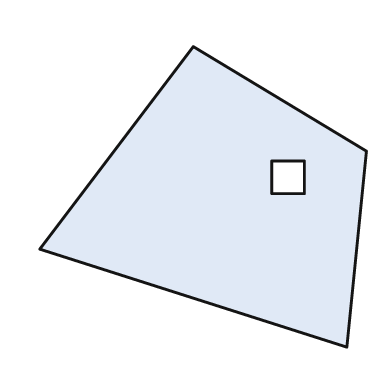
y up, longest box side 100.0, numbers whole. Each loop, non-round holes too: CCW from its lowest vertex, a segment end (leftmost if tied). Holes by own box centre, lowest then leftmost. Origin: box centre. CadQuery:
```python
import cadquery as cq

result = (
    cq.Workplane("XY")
    .moveTo(44.0, -46.0)
    .lineTo(50.0, 14.0)
    .lineTo(-3.0, 46.0)
    .lineTo(-50.0, -16.0)
    .close()
    .moveTo(21.0, 1.0)
    .lineTo(31.0, 1.0)
    .lineTo(31.0, 11.0)
    .lineTo(21.0, 11.0)
    .close()
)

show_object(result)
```